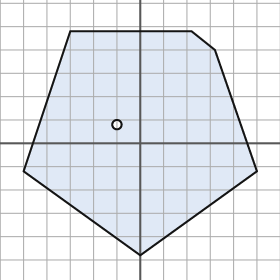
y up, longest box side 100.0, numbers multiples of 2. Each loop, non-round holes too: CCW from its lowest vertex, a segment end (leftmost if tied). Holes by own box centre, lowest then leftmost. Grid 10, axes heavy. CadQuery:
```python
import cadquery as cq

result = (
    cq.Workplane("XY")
    .moveTo(0.0, -48.0)
    .lineTo(50.0, -12.0)
    .lineTo(32.0, 40.0)
    .lineTo(22.0, 48.0)
    .lineTo(-30.0, 48.0)
    .lineTo(-50.0, -12.0)
    .close()
    .moveTo(-10.0, 8.0)
    .circle(2.0)
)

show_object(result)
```